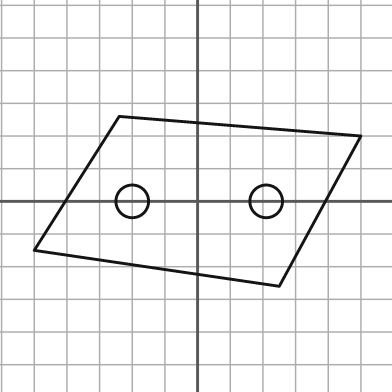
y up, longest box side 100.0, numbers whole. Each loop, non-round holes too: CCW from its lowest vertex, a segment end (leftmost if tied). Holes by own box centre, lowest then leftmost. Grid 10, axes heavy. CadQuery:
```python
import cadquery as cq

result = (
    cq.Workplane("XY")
    .moveTo(25.0, -26.0)
    .lineTo(50.0, 20.0)
    .lineTo(-24.0, 26.0)
    .lineTo(-50.0, -15.0)
    .close()
    .moveTo(-20.0, 0.0)
    .circle(5.0)
    .moveTo(21.0, 0.0)
    .circle(5.0)
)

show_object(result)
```